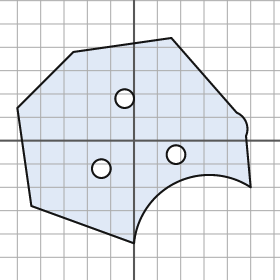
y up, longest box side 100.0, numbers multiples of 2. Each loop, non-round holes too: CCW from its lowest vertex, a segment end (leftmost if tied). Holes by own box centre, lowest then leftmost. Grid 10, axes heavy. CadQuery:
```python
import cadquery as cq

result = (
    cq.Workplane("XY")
    .moveTo(0.0, -44.0)
    .threePointArc((18.0, -18.0), (50.0, -20.0))
    .lineTo(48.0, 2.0)
    .threePointArc((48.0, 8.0), (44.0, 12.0))
    .lineTo(16.0, 44.0)
    .lineTo(-26.0, 38.0)
    .lineTo(-50.0, 14.0)
    .lineTo(-44.0, -28.0)
    .close()
    .moveTo(-14.0, -12.0)
    .circle(4.0)
    .moveTo(18.0, -6.0)
    .circle(4.0)
    .moveTo(-4.0, 18.0)
    .circle(4.0)
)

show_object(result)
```